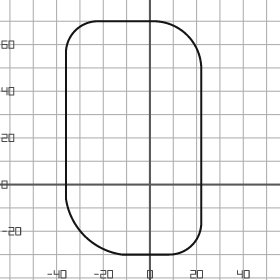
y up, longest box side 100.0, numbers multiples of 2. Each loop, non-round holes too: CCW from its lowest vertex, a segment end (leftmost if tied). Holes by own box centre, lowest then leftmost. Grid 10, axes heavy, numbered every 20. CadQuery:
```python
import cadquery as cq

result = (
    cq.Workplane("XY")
    .moveTo(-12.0, -30.0)
    .lineTo(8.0, -30.0)
    .threePointArc((18.0, -26.0), (22.0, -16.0))
    .lineTo(22.0, 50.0)
    .threePointArc((16.0, 64.0), (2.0, 70.0))
    .lineTo(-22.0, 70.0)
    .threePointArc((-32.0, 66.0), (-36.0, 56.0))
    .lineTo(-36.0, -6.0)
    .threePointArc((-28.0, -22.0), (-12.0, -30.0))
    .close()
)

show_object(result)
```